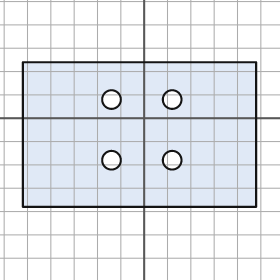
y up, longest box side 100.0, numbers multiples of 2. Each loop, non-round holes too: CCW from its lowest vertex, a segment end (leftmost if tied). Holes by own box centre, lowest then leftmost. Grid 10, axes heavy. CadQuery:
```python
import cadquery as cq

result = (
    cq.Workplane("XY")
    .moveTo(-52.0, -38.0)
    .lineTo(48.0, -38.0)
    .lineTo(48.0, 24.0)
    .lineTo(-52.0, 24.0)
    .close()
    .moveTo(-14.0, -18.0)
    .circle(4.0)
    .moveTo(12.0, -18.0)
    .circle(4.0)
    .moveTo(-14.0, 8.0)
    .circle(4.0)
    .moveTo(12.0, 8.0)
    .circle(4.0)
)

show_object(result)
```